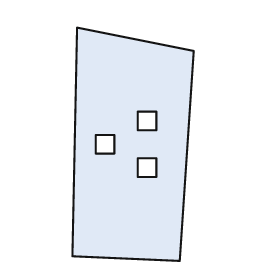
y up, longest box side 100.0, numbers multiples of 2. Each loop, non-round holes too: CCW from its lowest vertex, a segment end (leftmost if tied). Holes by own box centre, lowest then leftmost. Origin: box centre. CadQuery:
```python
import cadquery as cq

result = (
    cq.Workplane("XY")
    .moveTo(20.0, -50.0)
    .lineTo(26.0, 40.0)
    .lineTo(-24.0, 50.0)
    .lineTo(-26.0, -48.0)
    .close()
    .moveTo(2.0, -14.0)
    .lineTo(10.0, -14.0)
    .lineTo(10.0, -6.0)
    .lineTo(2.0, -6.0)
    .close()
    .moveTo(-16.0, -4.0)
    .lineTo(-8.0, -4.0)
    .lineTo(-8.0, 4.0)
    .lineTo(-16.0, 4.0)
    .close()
    .moveTo(2.0, 6.0)
    .lineTo(10.0, 6.0)
    .lineTo(10.0, 14.0)
    .lineTo(2.0, 14.0)
    .close()
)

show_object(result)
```